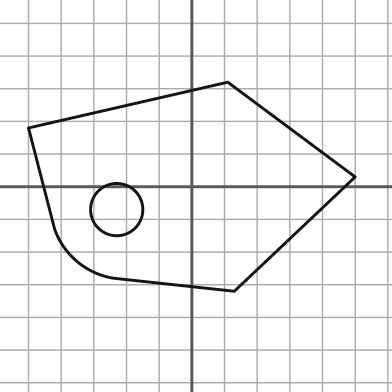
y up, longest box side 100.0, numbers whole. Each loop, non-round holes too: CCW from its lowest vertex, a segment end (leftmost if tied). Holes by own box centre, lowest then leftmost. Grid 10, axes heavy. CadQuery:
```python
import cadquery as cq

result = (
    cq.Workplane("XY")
    .moveTo(13.0, -32.0)
    .lineTo(50.0, 3.0)
    .lineTo(11.0, 32.0)
    .lineTo(-50.0, 18.0)
    .lineTo(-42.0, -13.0)
    .threePointArc((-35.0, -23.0), (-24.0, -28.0))
    .close()
    .moveTo(-23.0, -7.0)
    .circle(8.0)
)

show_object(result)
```